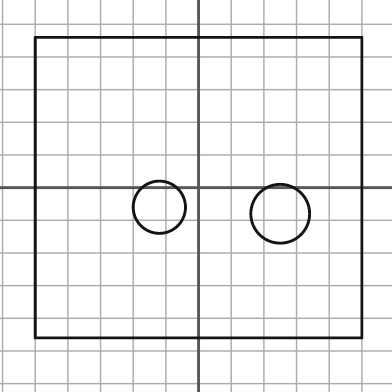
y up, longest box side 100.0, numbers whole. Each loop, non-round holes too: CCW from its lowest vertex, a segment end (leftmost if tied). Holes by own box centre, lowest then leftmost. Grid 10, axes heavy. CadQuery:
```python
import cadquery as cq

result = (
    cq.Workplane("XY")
    .moveTo(-50.0, -46.0)
    .lineTo(50.0, -46.0)
    .lineTo(50.0, 46.0)
    .lineTo(-50.0, 46.0)
    .close()
    .moveTo(25.0, -8.0)
    .circle(9.0)
    .moveTo(-12.0, -6.0)
    .circle(8.0)
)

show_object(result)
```